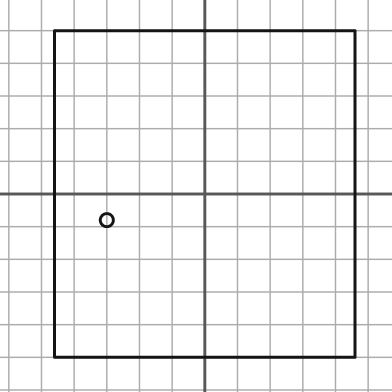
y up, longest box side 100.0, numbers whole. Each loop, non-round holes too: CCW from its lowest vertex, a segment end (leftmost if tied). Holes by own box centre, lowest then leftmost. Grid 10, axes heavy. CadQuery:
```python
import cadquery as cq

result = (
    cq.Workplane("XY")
    .moveTo(-46.0, -50.0)
    .lineTo(46.0, -50.0)
    .lineTo(46.0, 50.0)
    .lineTo(-46.0, 50.0)
    .close()
    .moveTo(-30.0, -8.0)
    .circle(2.0)
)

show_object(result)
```